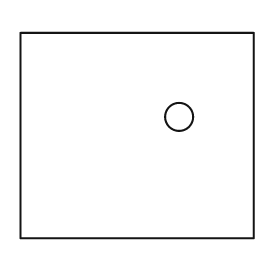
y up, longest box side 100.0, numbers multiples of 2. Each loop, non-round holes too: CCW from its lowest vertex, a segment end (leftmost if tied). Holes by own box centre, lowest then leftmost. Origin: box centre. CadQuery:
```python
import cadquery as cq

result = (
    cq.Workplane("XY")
    .moveTo(-50.0, -44.0)
    .lineTo(50.0, -44.0)
    .lineTo(50.0, 44.0)
    .lineTo(-50.0, 44.0)
    .close()
    .moveTo(18.0, 8.0)
    .circle(6.0)
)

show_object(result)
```